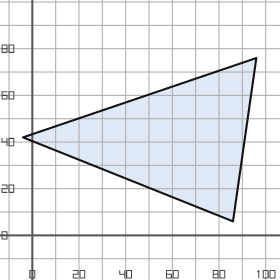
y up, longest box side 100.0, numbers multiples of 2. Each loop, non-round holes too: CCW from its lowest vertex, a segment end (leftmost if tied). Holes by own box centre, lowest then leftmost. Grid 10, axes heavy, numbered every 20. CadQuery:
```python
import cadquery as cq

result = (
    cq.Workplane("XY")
    .moveTo(86.0, 6.0)
    .lineTo(96.0, 76.0)
    .lineTo(-4.0, 42.0)
    .close()
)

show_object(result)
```